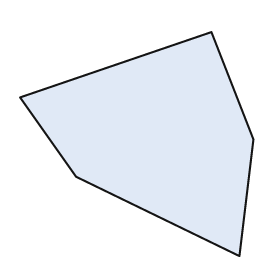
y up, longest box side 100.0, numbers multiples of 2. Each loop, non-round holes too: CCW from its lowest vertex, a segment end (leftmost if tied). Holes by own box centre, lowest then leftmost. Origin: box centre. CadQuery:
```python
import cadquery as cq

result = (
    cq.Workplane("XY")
    .moveTo(44.0, -48.0)
    .lineTo(50.0, 2.0)
    .lineTo(32.0, 48.0)
    .lineTo(-50.0, 20.0)
    .lineTo(-26.0, -14.0)
    .close()
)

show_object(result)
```